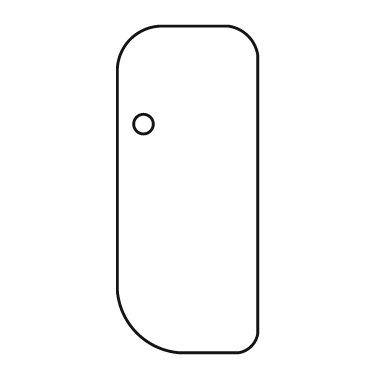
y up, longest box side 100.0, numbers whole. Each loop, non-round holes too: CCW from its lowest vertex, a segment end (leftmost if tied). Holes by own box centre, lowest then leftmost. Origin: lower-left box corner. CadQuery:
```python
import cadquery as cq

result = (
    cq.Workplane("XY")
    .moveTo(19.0, 0.0)
    .lineTo(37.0, 0.0)
    .threePointArc((41.0, 2.0), (43.0, 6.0))
    .lineTo(43.0, 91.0)
    .threePointArc((40.0, 97.0), (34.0, 100.0))
    .lineTo(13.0, 100.0)
    .threePointArc((4.0, 96.0), (0.0, 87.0))
    .lineTo(0.0, 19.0)
    .threePointArc((6.0, 6.0), (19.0, 0.0))
    .close()
    .moveTo(8.0, 70.0)
    .circle(3.0)
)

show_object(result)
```